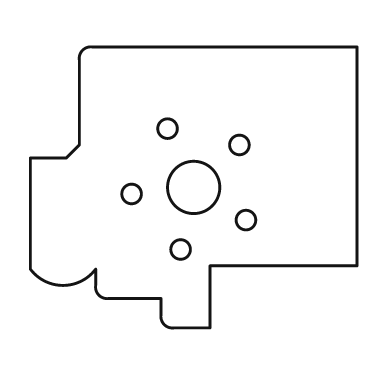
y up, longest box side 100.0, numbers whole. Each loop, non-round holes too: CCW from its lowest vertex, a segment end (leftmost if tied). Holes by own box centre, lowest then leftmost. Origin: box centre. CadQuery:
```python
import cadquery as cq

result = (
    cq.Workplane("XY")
    .moveTo(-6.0, -43.0)
    .lineTo(5.0, -43.0)
    .lineTo(5.0, -24.0)
    .lineTo(50.0, -24.0)
    .lineTo(50.0, 43.0)
    .lineTo(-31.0, 43.0)
    .threePointArc((-34.0, 42.0), (-35.0, 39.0))
    .lineTo(-35.0, 13.0)
    .lineTo(-39.0, 9.0)
    .lineTo(-50.0, 9.0)
    .lineTo(-50.0, -25.0)
    .threePointArc((-40.0, -30.0), (-30.0, -25.0))
    .lineTo(-30.0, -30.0)
    .threePointArc((-29.0, -33.0), (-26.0, -34.0))
    .lineTo(-10.0, -34.0)
    .lineTo(-10.0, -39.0)
    .threePointArc((-9.0, -42.0), (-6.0, -43.0))
    .close()
    .moveTo(-4.0, -19.0)
    .circle(3.0)
    .moveTo(16.0, -10.0)
    .circle(3.0)
    .moveTo(-19.0, -2.0)
    .circle(3.0)
    .moveTo(0.0, 0.0)
    .circle(8.0)
    .moveTo(14.0, 13.0)
    .circle(3.0)
    .moveTo(-8.0, 18.0)
    .circle(3.0)
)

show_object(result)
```